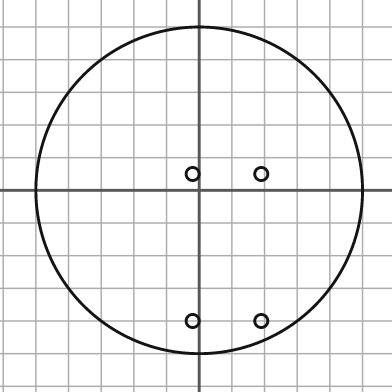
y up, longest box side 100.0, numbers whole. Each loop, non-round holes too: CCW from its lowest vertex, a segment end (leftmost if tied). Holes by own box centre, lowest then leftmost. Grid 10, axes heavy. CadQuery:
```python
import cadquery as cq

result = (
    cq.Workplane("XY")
    .moveTo(0.0, 0.0)
    .circle(50.0)
    .moveTo(-2.0, -40.0)
    .circle(2.0)
    .moveTo(19.0, -40.0)
    .circle(2.0)
    .moveTo(-2.0, 5.0)
    .circle(2.0)
    .moveTo(19.0, 5.0)
    .circle(2.0)
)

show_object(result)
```